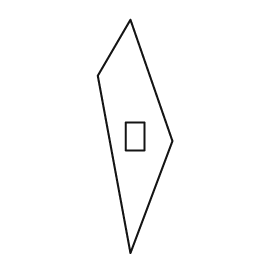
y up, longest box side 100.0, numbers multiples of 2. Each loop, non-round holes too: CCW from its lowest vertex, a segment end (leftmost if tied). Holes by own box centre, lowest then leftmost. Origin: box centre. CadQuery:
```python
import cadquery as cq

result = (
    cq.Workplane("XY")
    .moveTo(-2.0, -50.0)
    .lineTo(16.0, -2.0)
    .lineTo(-2.0, 50.0)
    .lineTo(-16.0, 26.0)
    .close()
    .moveTo(-4.0, -6.0)
    .lineTo(4.0, -6.0)
    .lineTo(4.0, 6.0)
    .lineTo(-4.0, 6.0)
    .close()
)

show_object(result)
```